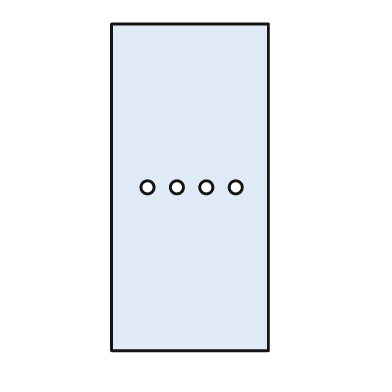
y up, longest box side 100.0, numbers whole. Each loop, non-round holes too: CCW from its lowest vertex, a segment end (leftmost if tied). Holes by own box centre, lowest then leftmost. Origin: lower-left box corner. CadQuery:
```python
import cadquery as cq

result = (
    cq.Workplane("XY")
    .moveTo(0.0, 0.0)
    .lineTo(48.0, 0.0)
    .lineTo(48.0, 100.0)
    .lineTo(0.0, 100.0)
    .close()
    .moveTo(11.0, 50.0)
    .circle(2.0)
    .moveTo(20.0, 50.0)
    .circle(2.0)
    .moveTo(29.0, 50.0)
    .circle(2.0)
    .moveTo(38.0, 50.0)
    .circle(2.0)
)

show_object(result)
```